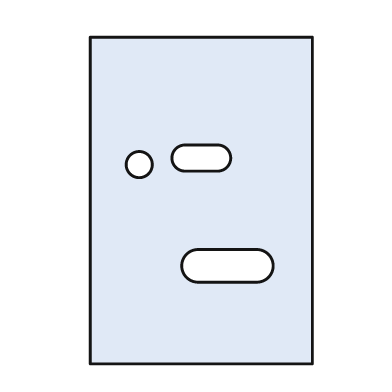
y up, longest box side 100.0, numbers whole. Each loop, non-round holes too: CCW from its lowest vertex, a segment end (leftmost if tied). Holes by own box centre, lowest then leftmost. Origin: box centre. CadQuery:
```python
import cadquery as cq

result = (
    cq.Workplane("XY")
    .moveTo(-34.0, -50.0)
    .lineTo(34.0, -50.0)
    .lineTo(34.0, 50.0)
    .lineTo(-34.0, 50.0)
    .close()
    .moveTo(-1.0, -25.0)
    .lineTo(17.0, -25.0)
    .threePointArc((22.0, -20.0), (17.0, -15.0))
    .lineTo(-1.0, -15.0)
    .threePointArc((-6.0, -20.0), (-1.0, -25.0))
    .close()
    .moveTo(-19.0, 11.0)
    .circle(4.0)
    .moveTo(-5.0, 9.0)
    .lineTo(5.0, 9.0)
    .threePointArc((9.0, 13.0), (5.0, 17.0))
    .lineTo(-5.0, 17.0)
    .threePointArc((-9.0, 13.0), (-5.0, 9.0))
    .close()
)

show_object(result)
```